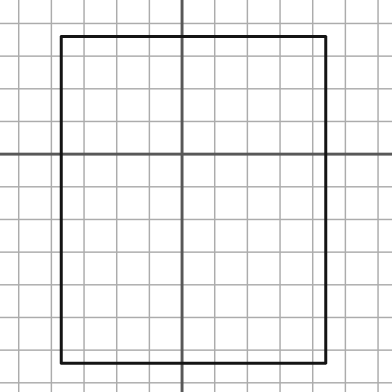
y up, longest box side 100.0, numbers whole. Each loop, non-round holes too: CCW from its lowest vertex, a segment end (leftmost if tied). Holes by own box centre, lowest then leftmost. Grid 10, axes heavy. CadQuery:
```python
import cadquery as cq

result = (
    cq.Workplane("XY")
    .moveTo(-37.0, -64.0)
    .lineTo(44.0, -64.0)
    .lineTo(44.0, 36.0)
    .lineTo(-37.0, 36.0)
    .close()
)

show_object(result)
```